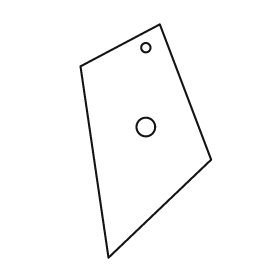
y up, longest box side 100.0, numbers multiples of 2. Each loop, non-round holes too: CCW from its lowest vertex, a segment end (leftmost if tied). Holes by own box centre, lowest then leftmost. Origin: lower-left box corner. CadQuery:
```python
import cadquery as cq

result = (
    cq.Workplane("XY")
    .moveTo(12.0, 0.0)
    .lineTo(56.0, 42.0)
    .lineTo(34.0, 100.0)
    .lineTo(0.0, 82.0)
    .close()
    .moveTo(28.0, 56.0)
    .circle(4.0)
    .moveTo(28.0, 90.0)
    .circle(2.0)
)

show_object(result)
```